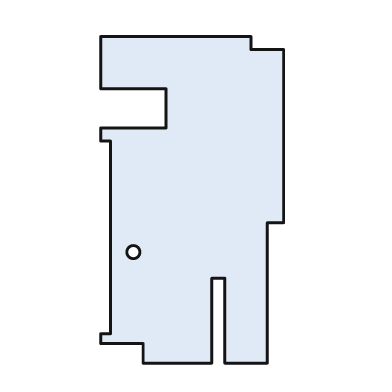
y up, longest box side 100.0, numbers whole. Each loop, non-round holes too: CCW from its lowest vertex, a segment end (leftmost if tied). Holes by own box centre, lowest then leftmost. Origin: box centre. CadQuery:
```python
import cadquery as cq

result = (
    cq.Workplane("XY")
    .moveTo(-15.0, -50.0)
    .lineTo(6.0, -50.0)
    .lineTo(6.0, -24.0)
    .lineTo(10.0, -24.0)
    .lineTo(10.0, -50.0)
    .lineTo(23.0, -50.0)
    .lineTo(23.0, -7.0)
    .lineTo(28.0, -7.0)
    .lineTo(28.0, 46.0)
    .lineTo(18.0, 46.0)
    .lineTo(18.0, 50.0)
    .lineTo(-28.0, 50.0)
    .lineTo(-28.0, 34.0)
    .lineTo(-8.0, 34.0)
    .lineTo(-8.0, 22.0)
    .lineTo(-28.0, 22.0)
    .lineTo(-28.0, 18.0)
    .lineTo(-25.0, 18.0)
    .lineTo(-25.0, -41.0)
    .lineTo(-28.0, -41.0)
    .lineTo(-28.0, -44.0)
    .lineTo(-15.0, -44.0)
    .close()
    .moveTo(-18.0, -16.0)
    .circle(2.0)
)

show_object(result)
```